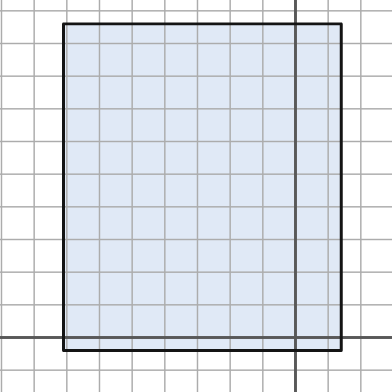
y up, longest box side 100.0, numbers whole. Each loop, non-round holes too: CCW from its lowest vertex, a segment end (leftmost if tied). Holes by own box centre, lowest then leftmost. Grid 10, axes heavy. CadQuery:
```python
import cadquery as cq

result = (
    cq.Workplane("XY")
    .moveTo(-71.0, -4.0)
    .lineTo(14.0, -4.0)
    .lineTo(14.0, 96.0)
    .lineTo(-71.0, 96.0)
    .close()
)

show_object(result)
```